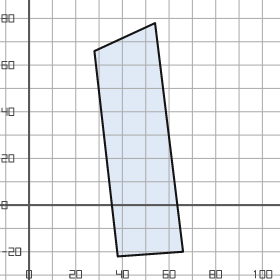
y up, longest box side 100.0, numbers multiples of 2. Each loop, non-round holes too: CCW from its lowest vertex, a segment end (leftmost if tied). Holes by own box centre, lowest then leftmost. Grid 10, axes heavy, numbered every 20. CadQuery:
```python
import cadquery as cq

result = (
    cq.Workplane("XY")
    .moveTo(38.0, -22.0)
    .lineTo(66.0, -20.0)
    .lineTo(54.0, 78.0)
    .lineTo(28.0, 66.0)
    .close()
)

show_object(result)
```